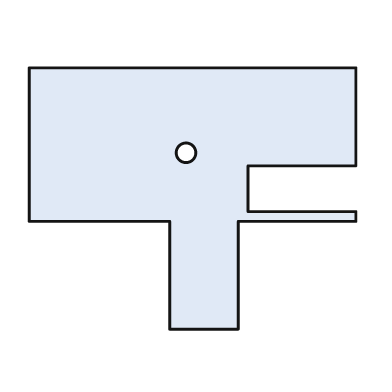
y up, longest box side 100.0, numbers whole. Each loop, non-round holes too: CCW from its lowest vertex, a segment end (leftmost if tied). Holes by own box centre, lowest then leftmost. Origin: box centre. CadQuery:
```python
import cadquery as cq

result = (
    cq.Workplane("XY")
    .moveTo(-7.0, -40.0)
    .lineTo(14.0, -40.0)
    .lineTo(14.0, -7.0)
    .lineTo(50.0, -7.0)
    .lineTo(50.0, -4.0)
    .lineTo(17.0, -4.0)
    .lineTo(17.0, 10.0)
    .lineTo(50.0, 10.0)
    .lineTo(50.0, 40.0)
    .lineTo(-50.0, 40.0)
    .lineTo(-50.0, -7.0)
    .lineTo(-7.0, -7.0)
    .close()
    .moveTo(-2.0, 14.0)
    .circle(3.0)
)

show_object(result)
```